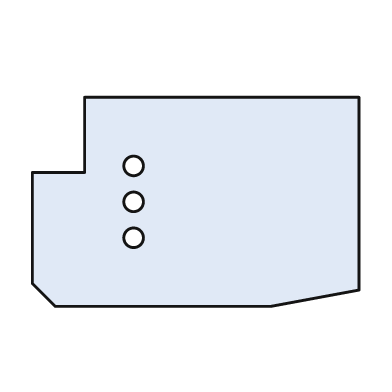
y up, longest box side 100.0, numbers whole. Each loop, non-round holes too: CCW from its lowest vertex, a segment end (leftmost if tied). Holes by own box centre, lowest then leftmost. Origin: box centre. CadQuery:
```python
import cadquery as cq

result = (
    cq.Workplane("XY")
    .moveTo(-43.0, -32.0)
    .lineTo(23.0, -32.0)
    .lineTo(50.0, -27.0)
    .lineTo(50.0, 32.0)
    .lineTo(-34.0, 32.0)
    .lineTo(-34.0, 9.0)
    .lineTo(-50.0, 9.0)
    .lineTo(-50.0, -25.0)
    .close()
    .moveTo(-19.0, -11.0)
    .circle(3.0)
    .moveTo(-19.0, 0.0)
    .circle(3.0)
    .moveTo(-19.0, 11.0)
    .circle(3.0)
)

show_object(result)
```